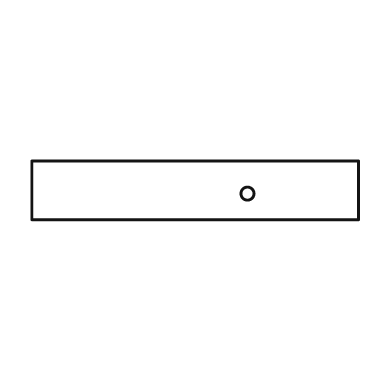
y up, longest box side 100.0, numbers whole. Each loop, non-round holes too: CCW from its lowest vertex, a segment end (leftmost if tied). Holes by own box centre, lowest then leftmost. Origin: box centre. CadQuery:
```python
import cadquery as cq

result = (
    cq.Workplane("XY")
    .moveTo(-50.0, -9.0)
    .lineTo(50.0, -9.0)
    .lineTo(50.0, 9.0)
    .lineTo(-50.0, 9.0)
    .close()
    .moveTo(16.0, -1.0)
    .circle(2.0)
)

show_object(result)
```